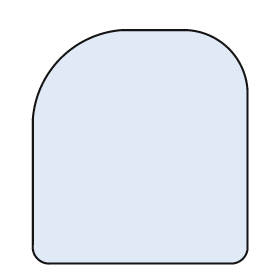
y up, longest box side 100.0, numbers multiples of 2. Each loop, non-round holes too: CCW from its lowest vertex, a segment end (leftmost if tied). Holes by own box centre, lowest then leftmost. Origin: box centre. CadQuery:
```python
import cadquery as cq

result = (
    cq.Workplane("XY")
    .moveTo(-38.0, -50.0)
    .lineTo(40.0, -50.0)
    .threePointArc((44.0, -48.0), (46.0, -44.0))
    .lineTo(46.0, 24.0)
    .threePointArc((38.0, 42.0), (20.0, 50.0))
    .lineTo(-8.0, 50.0)
    .threePointArc((-34.0, 38.0), (-46.0, 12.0))
    .lineTo(-46.0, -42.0)
    .threePointArc((-44.0, -48.0), (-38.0, -50.0))
    .close()
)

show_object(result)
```